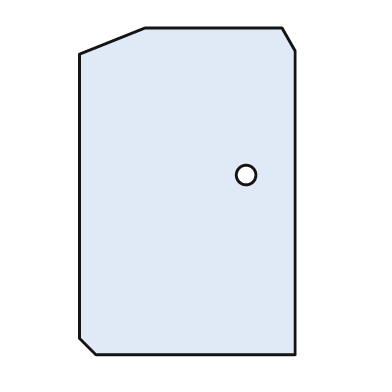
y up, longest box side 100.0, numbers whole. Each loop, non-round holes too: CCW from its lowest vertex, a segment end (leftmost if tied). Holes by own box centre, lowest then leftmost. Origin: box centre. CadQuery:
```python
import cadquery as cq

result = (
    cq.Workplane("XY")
    .moveTo(-28.0, -50.0)
    .lineTo(33.0, -50.0)
    .lineTo(33.0, 43.0)
    .lineTo(29.0, 50.0)
    .lineTo(-13.0, 50.0)
    .lineTo(-33.0, 42.0)
    .lineTo(-33.0, -45.0)
    .close()
    .moveTo(18.0, 5.0)
    .circle(3.0)
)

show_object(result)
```